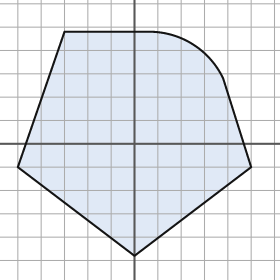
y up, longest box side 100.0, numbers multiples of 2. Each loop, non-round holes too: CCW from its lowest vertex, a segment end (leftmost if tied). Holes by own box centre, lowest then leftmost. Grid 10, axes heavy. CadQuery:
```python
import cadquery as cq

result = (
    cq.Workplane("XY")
    .moveTo(0.0, -48.0)
    .lineTo(50.0, -10.0)
    .lineTo(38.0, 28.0)
    .threePointArc((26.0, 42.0), (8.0, 48.0))
    .lineTo(-30.0, 48.0)
    .lineTo(-50.0, -10.0)
    .close()
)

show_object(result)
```